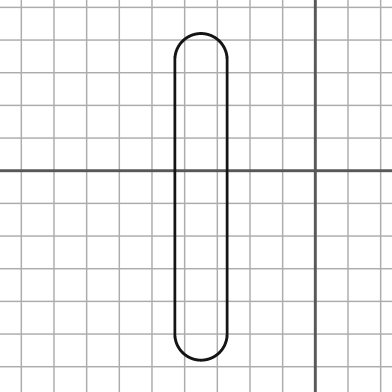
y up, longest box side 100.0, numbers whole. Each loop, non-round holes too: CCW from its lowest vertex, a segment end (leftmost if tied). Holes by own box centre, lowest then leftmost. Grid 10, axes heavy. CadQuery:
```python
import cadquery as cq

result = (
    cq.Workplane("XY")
    .moveTo(-43.0, -50.0)
    .threePointArc((-35.0, -58.0), (-27.0, -50.0))
    .lineTo(-27.0, 34.0)
    .threePointArc((-35.0, 42.0), (-43.0, 34.0))
    .close()
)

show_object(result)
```